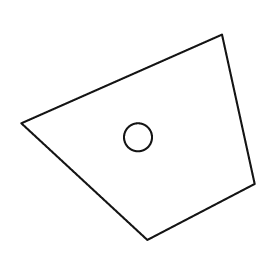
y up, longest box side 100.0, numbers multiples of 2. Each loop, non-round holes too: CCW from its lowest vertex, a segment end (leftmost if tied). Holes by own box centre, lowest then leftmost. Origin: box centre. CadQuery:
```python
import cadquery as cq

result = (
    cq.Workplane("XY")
    .moveTo(4.0, -44.0)
    .lineTo(50.0, -20.0)
    .lineTo(36.0, 44.0)
    .lineTo(-50.0, 6.0)
    .close()
    .moveTo(0.0, 0.0)
    .circle(6.0)
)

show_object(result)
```